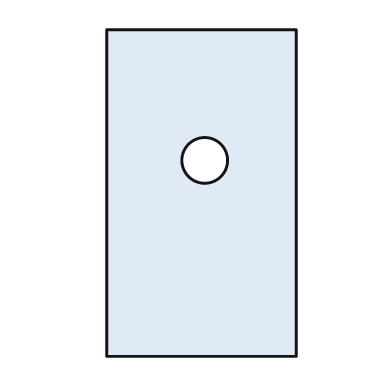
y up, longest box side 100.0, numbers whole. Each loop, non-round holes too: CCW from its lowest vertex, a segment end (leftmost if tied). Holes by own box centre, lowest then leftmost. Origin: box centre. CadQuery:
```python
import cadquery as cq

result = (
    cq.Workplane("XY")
    .moveTo(-29.0, -50.0)
    .lineTo(29.0, -50.0)
    .lineTo(29.0, 50.0)
    .lineTo(-29.0, 50.0)
    .close()
    .moveTo(1.0, 10.0)
    .circle(7.0)
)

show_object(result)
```